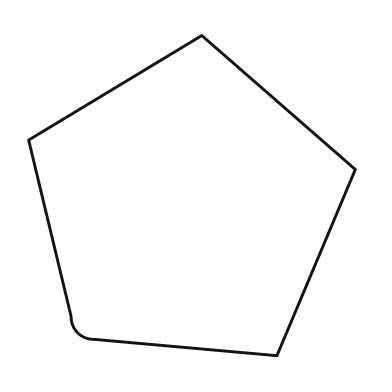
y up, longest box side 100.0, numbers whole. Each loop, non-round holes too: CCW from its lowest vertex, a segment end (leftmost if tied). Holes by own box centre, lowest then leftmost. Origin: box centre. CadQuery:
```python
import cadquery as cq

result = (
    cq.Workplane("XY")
    .moveTo(26.0, -49.0)
    .lineTo(50.0, 8.0)
    .lineTo(3.0, 49.0)
    .lineTo(-50.0, 17.0)
    .lineTo(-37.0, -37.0)
    .threePointArc((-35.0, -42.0), (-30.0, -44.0))
    .close()
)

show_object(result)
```